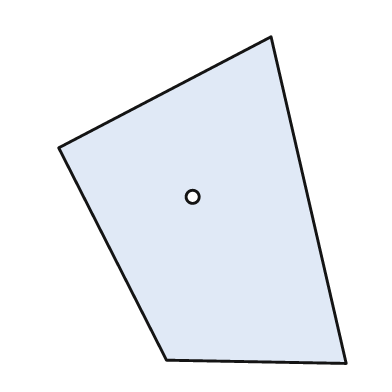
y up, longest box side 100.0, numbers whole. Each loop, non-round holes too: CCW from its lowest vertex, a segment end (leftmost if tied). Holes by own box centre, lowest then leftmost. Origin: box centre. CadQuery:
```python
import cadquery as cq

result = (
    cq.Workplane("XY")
    .moveTo(44.0, -50.0)
    .lineTo(21.0, 50.0)
    .lineTo(-44.0, 16.0)
    .lineTo(-11.0, -49.0)
    .close()
    .moveTo(-3.0, 1.0)
    .circle(2.0)
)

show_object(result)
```